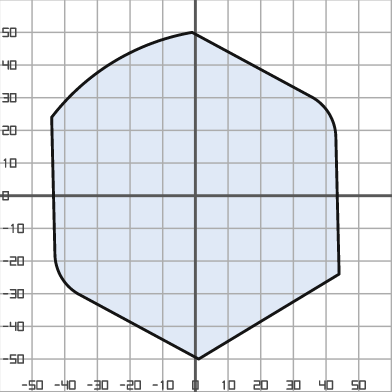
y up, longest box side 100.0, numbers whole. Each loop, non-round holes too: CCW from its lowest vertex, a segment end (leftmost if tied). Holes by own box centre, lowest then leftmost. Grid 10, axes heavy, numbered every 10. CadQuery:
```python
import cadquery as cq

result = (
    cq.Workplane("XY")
    .moveTo(1.0, -50.0)
    .lineTo(44.0, -24.0)
    .lineTo(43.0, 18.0)
    .threePointArc((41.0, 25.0), (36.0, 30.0))
    .lineTo(-1.0, 50.0)
    .threePointArc((-25.0, 41.0), (-44.0, 24.0))
    .lineTo(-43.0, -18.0)
    .threePointArc((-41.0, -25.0), (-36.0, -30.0))
    .close()
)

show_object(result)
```